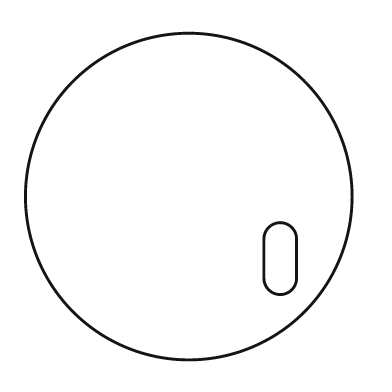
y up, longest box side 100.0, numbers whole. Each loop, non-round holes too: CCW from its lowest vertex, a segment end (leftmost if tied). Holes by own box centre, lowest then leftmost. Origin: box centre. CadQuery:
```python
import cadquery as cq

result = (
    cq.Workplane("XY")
    .moveTo(0.0, 0.0)
    .circle(50.0)
    .moveTo(23.0, -25.0)
    .threePointArc((28.0, -30.0), (33.0, -25.0))
    .lineTo(33.0, -13.0)
    .threePointArc((28.0, -8.0), (23.0, -13.0))
    .close()
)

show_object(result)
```